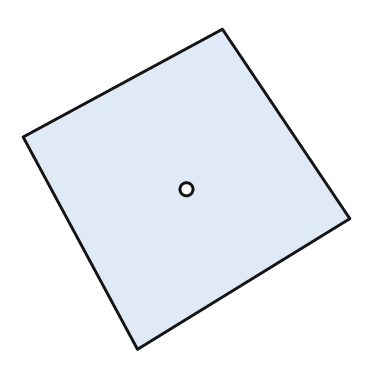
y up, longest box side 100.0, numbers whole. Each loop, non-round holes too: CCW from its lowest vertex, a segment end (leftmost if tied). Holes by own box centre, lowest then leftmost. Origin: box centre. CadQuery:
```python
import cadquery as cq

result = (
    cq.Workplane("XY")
    .moveTo(-15.0, -49.0)
    .lineTo(50.0, -9.0)
    .lineTo(11.0, 49.0)
    .lineTo(-50.0, 16.0)
    .close()
    .moveTo(0.0, 0.0)
    .circle(2.0)
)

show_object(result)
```